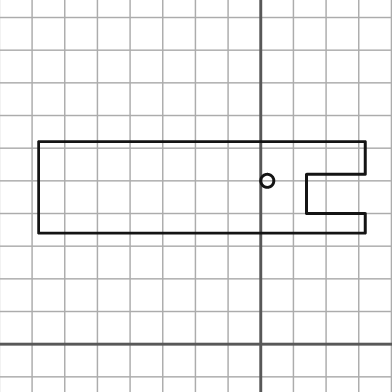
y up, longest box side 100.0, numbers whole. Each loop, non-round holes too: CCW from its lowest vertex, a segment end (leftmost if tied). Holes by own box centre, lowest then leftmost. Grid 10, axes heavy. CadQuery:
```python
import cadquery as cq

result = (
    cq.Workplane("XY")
    .moveTo(-68.0, 34.0)
    .lineTo(32.0, 34.0)
    .lineTo(32.0, 40.0)
    .lineTo(14.0, 40.0)
    .lineTo(14.0, 52.0)
    .lineTo(32.0, 52.0)
    .lineTo(32.0, 62.0)
    .lineTo(-68.0, 62.0)
    .close()
    .moveTo(2.0, 50.0)
    .circle(2.0)
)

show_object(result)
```